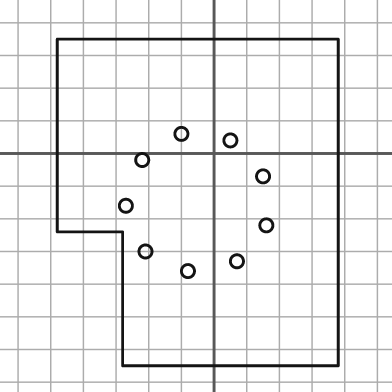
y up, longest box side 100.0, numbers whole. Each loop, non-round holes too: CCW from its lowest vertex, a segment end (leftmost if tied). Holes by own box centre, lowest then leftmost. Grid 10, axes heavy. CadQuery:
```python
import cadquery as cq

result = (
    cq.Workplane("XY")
    .moveTo(-28.0, -65.0)
    .lineTo(38.0, -65.0)
    .lineTo(38.0, 35.0)
    .lineTo(-48.0, 35.0)
    .lineTo(-48.0, -24.0)
    .lineTo(-28.0, -24.0)
    .close()
    .moveTo(-8.0, -36.0)
    .circle(2.0)
    .moveTo(7.0, -33.0)
    .circle(2.0)
    .moveTo(-21.0, -30.0)
    .circle(2.0)
    .moveTo(16.0, -22.0)
    .circle(2.0)
    .moveTo(-27.0, -16.0)
    .circle(2.0)
    .moveTo(15.0, -7.0)
    .circle(2.0)
    .moveTo(-22.0, -2.0)
    .circle(2.0)
    .moveTo(5.0, 4.0)
    .circle(2.0)
    .moveTo(-10.0, 6.0)
    .circle(2.0)
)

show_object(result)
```